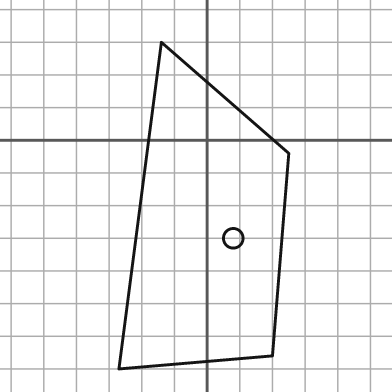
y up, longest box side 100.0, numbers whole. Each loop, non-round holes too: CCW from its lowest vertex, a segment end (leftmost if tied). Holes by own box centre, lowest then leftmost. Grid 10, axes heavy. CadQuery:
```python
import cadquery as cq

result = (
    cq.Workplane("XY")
    .moveTo(-27.0, -70.0)
    .lineTo(20.0, -66.0)
    .lineTo(25.0, -4.0)
    .lineTo(-14.0, 30.0)
    .close()
    .moveTo(8.0, -30.0)
    .circle(3.0)
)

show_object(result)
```